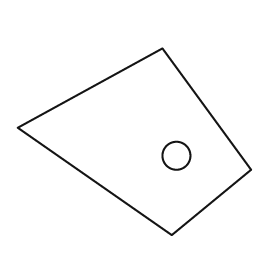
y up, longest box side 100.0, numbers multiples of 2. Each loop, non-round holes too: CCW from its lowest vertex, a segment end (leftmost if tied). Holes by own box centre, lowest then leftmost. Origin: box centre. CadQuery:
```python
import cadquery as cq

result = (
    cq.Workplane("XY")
    .moveTo(16.0, -40.0)
    .lineTo(50.0, -12.0)
    .lineTo(12.0, 40.0)
    .lineTo(-50.0, 6.0)
    .close()
    .moveTo(18.0, -6.0)
    .circle(6.0)
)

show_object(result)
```